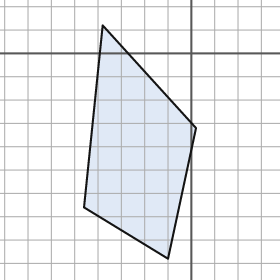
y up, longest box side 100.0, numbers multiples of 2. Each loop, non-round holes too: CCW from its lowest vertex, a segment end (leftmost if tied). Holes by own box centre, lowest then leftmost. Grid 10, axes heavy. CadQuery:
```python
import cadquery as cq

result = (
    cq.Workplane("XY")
    .moveTo(-10.0, -88.0)
    .lineTo(2.0, -32.0)
    .lineTo(-38.0, 12.0)
    .lineTo(-46.0, -66.0)
    .close()
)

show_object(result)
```